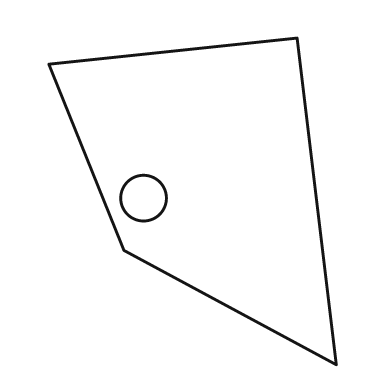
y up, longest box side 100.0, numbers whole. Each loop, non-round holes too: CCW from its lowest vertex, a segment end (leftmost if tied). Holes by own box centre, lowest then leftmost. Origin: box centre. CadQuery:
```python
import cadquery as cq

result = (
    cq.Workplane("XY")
    .moveTo(44.0, -50.0)
    .lineTo(32.0, 50.0)
    .lineTo(-44.0, 42.0)
    .lineTo(-21.0, -15.0)
    .close()
    .moveTo(-15.0, 1.0)
    .circle(7.0)
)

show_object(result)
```